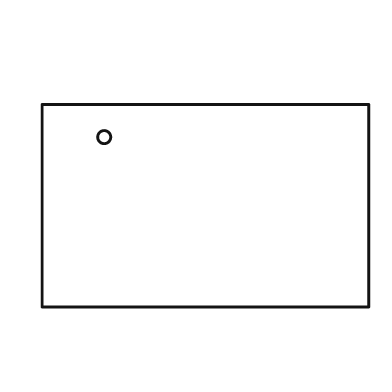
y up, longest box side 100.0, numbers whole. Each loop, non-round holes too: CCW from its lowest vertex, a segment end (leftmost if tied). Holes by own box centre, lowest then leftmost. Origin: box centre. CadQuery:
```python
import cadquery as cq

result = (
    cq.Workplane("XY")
    .moveTo(-50.0, -31.0)
    .lineTo(50.0, -31.0)
    .lineTo(50.0, 31.0)
    .lineTo(-50.0, 31.0)
    .close()
    .moveTo(-31.0, 21.0)
    .circle(2.0)
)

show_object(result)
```